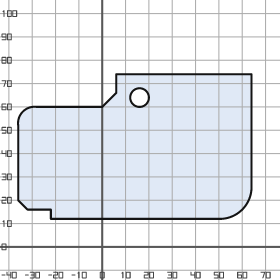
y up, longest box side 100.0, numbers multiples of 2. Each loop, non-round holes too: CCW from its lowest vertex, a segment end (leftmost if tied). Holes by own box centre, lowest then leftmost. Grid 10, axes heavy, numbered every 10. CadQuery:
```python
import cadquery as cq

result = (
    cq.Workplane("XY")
    .moveTo(-22.0, 12.0)
    .lineTo(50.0, 12.0)
    .threePointArc((60.0, 16.0), (64.0, 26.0))
    .lineTo(64.0, 74.0)
    .lineTo(6.0, 74.0)
    .lineTo(6.0, 66.0)
    .lineTo(0.0, 60.0)
    .lineTo(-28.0, 60.0)
    .threePointArc((-34.0, 58.0), (-36.0, 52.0))
    .lineTo(-36.0, 20.0)
    .lineTo(-32.0, 16.0)
    .lineTo(-22.0, 16.0)
    .close()
    .moveTo(16.0, 64.0)
    .circle(4.0)
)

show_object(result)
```